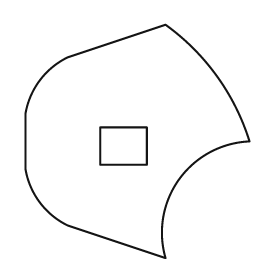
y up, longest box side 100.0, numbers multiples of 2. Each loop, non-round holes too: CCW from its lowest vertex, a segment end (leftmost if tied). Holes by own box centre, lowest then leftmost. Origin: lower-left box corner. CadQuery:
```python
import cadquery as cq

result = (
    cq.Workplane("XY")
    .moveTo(60.0, 0.0)
    .threePointArc((66.0, 34.0), (96.0, 50.0))
    .threePointArc((82.0, 78.0), (60.0, 100.0))
    .lineTo(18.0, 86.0)
    .threePointArc((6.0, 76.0), (0.0, 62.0))
    .lineTo(0.0, 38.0)
    .threePointArc((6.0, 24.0), (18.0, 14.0))
    .close()
    .moveTo(32.0, 40.0)
    .lineTo(52.0, 40.0)
    .lineTo(52.0, 56.0)
    .lineTo(32.0, 56.0)
    .close()
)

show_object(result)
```